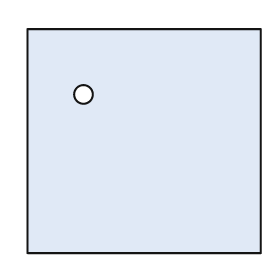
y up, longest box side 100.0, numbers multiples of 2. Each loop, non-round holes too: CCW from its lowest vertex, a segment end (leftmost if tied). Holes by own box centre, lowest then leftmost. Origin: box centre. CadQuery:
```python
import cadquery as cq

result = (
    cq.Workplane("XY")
    .moveTo(-50.0, -48.0)
    .lineTo(50.0, -48.0)
    .lineTo(50.0, 48.0)
    .lineTo(-50.0, 48.0)
    .close()
    .moveTo(-26.0, 20.0)
    .circle(4.0)
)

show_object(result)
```